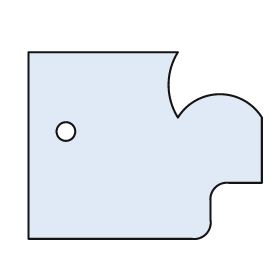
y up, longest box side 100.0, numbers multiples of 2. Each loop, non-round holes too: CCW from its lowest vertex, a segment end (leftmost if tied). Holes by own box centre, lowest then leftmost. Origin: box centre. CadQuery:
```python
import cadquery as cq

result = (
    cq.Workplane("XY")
    .moveTo(-50.0, -40.0)
    .lineTo(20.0, -40.0)
    .threePointArc((26.0, -38.0), (28.0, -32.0))
    .lineTo(28.0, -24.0)
    .threePointArc((30.0, -18.0), (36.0, -16.0))
    .lineTo(50.0, -16.0)
    .lineTo(50.0, 12.0)
    .threePointArc((32.0, 22.0), (14.0, 12.0))
    .threePointArc((10.0, 26.0), (14.0, 40.0))
    .lineTo(-50.0, 40.0)
    .close()
    .moveTo(-34.0, 6.0)
    .circle(4.0)
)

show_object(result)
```